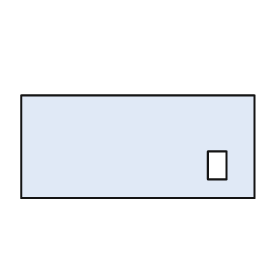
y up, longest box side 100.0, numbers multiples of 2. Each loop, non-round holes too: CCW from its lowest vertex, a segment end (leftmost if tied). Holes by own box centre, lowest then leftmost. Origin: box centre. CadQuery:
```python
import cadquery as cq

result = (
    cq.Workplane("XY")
    .moveTo(-50.0, -22.0)
    .lineTo(50.0, -22.0)
    .lineTo(50.0, 22.0)
    .lineTo(-50.0, 22.0)
    .close()
    .moveTo(30.0, -14.0)
    .lineTo(38.0, -14.0)
    .lineTo(38.0, -2.0)
    .lineTo(30.0, -2.0)
    .close()
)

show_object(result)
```